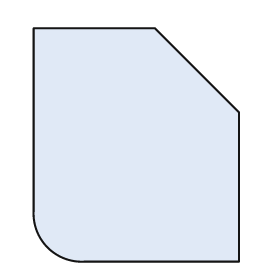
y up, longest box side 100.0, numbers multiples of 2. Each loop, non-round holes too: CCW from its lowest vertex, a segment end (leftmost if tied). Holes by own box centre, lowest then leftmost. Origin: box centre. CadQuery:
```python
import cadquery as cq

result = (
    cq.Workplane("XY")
    .moveTo(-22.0, -50.0)
    .lineTo(44.0, -50.0)
    .lineTo(44.0, 14.0)
    .lineTo(8.0, 50.0)
    .lineTo(-44.0, 50.0)
    .lineTo(-44.0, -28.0)
    .threePointArc((-38.0, -44.0), (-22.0, -50.0))
    .close()
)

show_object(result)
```